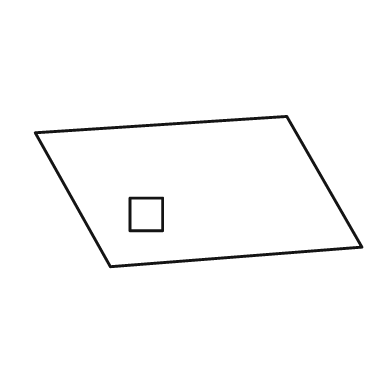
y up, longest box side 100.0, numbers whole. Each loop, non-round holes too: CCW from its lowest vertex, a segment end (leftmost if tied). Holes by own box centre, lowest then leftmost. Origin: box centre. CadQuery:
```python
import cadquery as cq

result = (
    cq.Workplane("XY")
    .moveTo(-27.0, -23.0)
    .lineTo(50.0, -17.0)
    .lineTo(27.0, 23.0)
    .lineTo(-50.0, 18.0)
    .close()
    .moveTo(-21.0, -12.0)
    .lineTo(-11.0, -12.0)
    .lineTo(-11.0, -2.0)
    .lineTo(-21.0, -2.0)
    .close()
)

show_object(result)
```